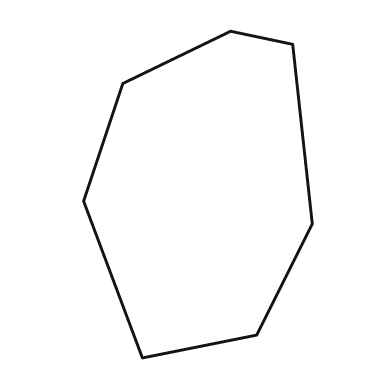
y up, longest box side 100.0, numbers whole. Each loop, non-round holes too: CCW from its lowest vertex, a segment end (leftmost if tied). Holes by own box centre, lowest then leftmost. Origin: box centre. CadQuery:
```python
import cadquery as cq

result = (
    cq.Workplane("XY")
    .moveTo(-17.0, -50.0)
    .lineTo(18.0, -43.0)
    .lineTo(35.0, -9.0)
    .lineTo(29.0, 46.0)
    .lineTo(10.0, 50.0)
    .lineTo(-23.0, 34.0)
    .lineTo(-35.0, -2.0)
    .close()
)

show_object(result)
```